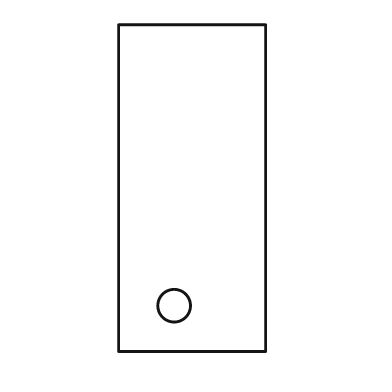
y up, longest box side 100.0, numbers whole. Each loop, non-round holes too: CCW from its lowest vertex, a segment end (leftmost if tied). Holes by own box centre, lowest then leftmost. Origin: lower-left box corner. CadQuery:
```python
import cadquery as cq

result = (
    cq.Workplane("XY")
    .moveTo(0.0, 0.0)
    .lineTo(45.0, 0.0)
    .lineTo(45.0, 100.0)
    .lineTo(0.0, 100.0)
    .close()
    .moveTo(17.0, 14.0)
    .circle(5.0)
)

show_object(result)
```